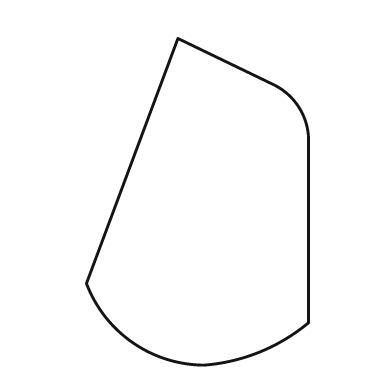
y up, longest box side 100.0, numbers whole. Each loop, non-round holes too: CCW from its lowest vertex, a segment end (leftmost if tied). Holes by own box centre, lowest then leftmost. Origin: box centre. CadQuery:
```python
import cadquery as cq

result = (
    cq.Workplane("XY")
    .moveTo(2.0, -50.0)
    .threePointArc((19.0, -46.0), (34.0, -37.0))
    .lineTo(34.0, 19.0)
    .threePointArc((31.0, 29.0), (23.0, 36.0))
    .lineTo(-6.0, 50.0)
    .lineTo(-34.0, -25.0)
    .threePointArc((-20.0, -43.0), (2.0, -50.0))
    .close()
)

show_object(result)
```